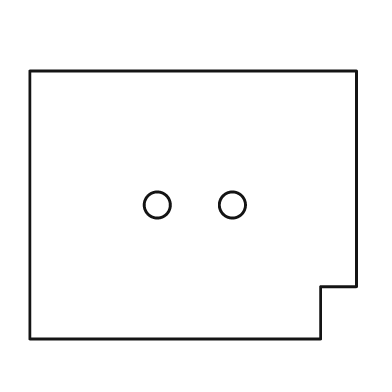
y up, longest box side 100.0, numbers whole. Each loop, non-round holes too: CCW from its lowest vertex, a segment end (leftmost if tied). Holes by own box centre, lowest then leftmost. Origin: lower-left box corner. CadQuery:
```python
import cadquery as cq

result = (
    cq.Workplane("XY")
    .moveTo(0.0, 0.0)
    .lineTo(89.0, 0.0)
    .lineTo(89.0, 16.0)
    .lineTo(100.0, 16.0)
    .lineTo(100.0, 82.0)
    .lineTo(0.0, 82.0)
    .close()
    .moveTo(39.0, 41.0)
    .circle(4.0)
    .moveTo(62.0, 41.0)
    .circle(4.0)
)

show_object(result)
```